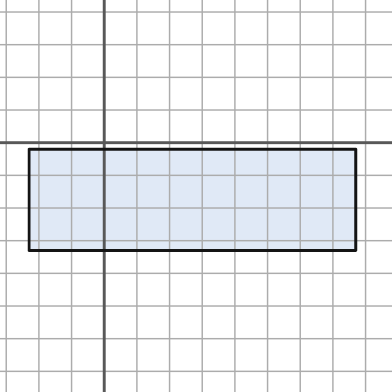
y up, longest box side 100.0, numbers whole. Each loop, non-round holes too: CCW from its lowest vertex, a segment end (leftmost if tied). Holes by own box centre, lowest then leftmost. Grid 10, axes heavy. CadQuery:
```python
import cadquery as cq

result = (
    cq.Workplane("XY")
    .moveTo(-23.0, -33.0)
    .lineTo(77.0, -33.0)
    .lineTo(77.0, -2.0)
    .lineTo(-23.0, -2.0)
    .close()
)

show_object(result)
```